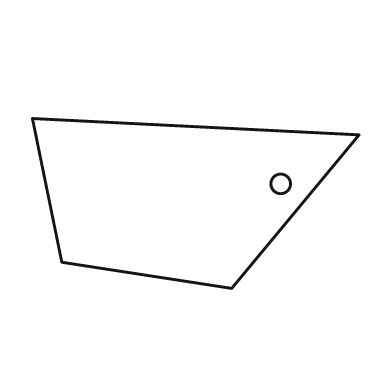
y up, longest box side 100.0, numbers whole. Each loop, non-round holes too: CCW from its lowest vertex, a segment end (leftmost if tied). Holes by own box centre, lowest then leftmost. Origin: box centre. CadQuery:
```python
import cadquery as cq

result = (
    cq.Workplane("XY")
    .moveTo(11.0, -26.0)
    .lineTo(50.0, 21.0)
    .lineTo(-50.0, 26.0)
    .lineTo(-41.0, -18.0)
    .close()
    .moveTo(26.0, 6.0)
    .circle(3.0)
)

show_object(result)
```